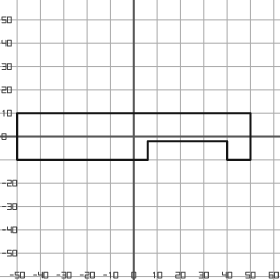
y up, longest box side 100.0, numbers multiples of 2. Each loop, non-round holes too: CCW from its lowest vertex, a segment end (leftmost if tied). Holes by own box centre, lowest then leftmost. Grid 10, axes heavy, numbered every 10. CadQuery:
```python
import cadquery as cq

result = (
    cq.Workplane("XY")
    .moveTo(-50.0, -10.0)
    .lineTo(6.0, -10.0)
    .lineTo(6.0, -2.0)
    .lineTo(40.0, -2.0)
    .lineTo(40.0, -10.0)
    .lineTo(50.0, -10.0)
    .lineTo(50.0, 10.0)
    .lineTo(-50.0, 10.0)
    .close()
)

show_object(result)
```